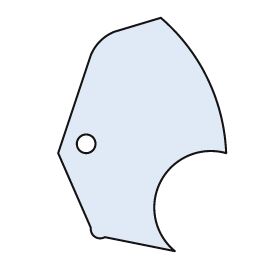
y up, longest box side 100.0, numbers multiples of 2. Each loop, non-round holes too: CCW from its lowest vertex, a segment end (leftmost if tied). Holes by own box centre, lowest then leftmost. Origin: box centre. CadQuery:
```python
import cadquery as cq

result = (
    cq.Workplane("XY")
    .moveTo(14.0, -50.0)
    .threePointArc((8.0, -20.0), (36.0, -8.0))
    .threePointArc((28.0, 24.0), (8.0, 50.0))
    .lineTo(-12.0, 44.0)
    .threePointArc((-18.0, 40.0), (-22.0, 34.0))
    .lineTo(-36.0, -8.0)
    .lineTo(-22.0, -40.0)
    .threePointArc((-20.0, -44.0), (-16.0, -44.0))
    .close()
    .moveTo(-24.0, -4.0)
    .circle(4.0)
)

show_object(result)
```